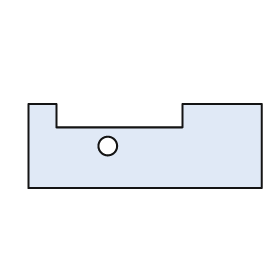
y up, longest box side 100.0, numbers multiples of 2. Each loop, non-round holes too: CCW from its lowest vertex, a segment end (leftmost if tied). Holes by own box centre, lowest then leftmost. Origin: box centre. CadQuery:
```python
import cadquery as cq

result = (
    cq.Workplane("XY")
    .moveTo(-50.0, -18.0)
    .lineTo(50.0, -18.0)
    .lineTo(50.0, 18.0)
    .lineTo(16.0, 18.0)
    .lineTo(16.0, 8.0)
    .lineTo(-38.0, 8.0)
    .lineTo(-38.0, 18.0)
    .lineTo(-50.0, 18.0)
    .close()
    .moveTo(-16.0, 0.0)
    .circle(4.0)
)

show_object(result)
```